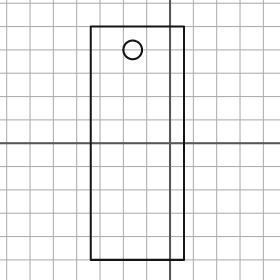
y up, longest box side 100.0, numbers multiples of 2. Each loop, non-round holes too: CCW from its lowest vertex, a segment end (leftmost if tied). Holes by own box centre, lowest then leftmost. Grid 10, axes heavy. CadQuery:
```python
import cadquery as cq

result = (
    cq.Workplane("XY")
    .moveTo(-34.0, -50.0)
    .lineTo(6.0, -50.0)
    .lineTo(6.0, 50.0)
    .lineTo(-34.0, 50.0)
    .close()
    .moveTo(-16.0, 40.0)
    .circle(4.0)
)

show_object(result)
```